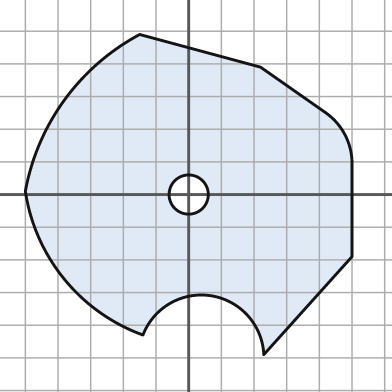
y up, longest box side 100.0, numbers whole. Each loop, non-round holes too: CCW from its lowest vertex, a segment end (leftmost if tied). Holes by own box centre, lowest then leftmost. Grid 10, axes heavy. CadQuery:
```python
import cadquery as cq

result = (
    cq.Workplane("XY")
    .moveTo(23.0, -49.0)
    .lineTo(50.0, -19.0)
    .lineTo(50.0, 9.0)
    .threePointArc((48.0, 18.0), (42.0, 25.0))
    .lineTo(22.0, 39.0)
    .lineTo(-15.0, 49.0)
    .threePointArc((-38.0, 29.0), (-50.0, 1.0))
    .threePointArc((-38.0, -26.0), (-14.0, -43.0))
    .threePointArc((7.0, -31.0), (23.0, -49.0))
    .close()
    .moveTo(0.0, 0.0)
    .circle(6.0)
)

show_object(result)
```